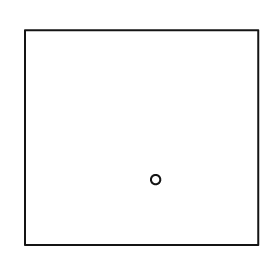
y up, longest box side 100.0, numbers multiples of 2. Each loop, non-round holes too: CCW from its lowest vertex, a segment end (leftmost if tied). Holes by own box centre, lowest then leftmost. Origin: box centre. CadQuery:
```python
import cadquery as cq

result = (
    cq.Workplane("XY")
    .moveTo(-50.0, -46.0)
    .lineTo(50.0, -46.0)
    .lineTo(50.0, 46.0)
    .lineTo(-50.0, 46.0)
    .close()
    .moveTo(6.0, -18.0)
    .circle(2.0)
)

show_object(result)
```